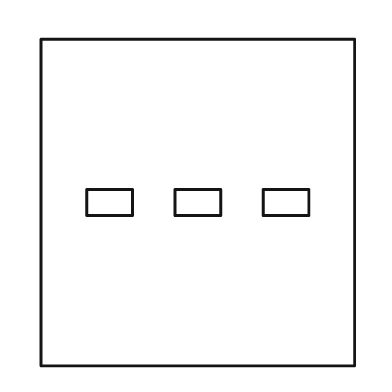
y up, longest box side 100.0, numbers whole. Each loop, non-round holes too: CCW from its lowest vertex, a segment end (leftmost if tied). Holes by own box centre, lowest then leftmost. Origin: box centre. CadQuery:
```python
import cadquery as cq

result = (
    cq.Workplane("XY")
    .moveTo(-48.0, -50.0)
    .lineTo(48.0, -50.0)
    .lineTo(48.0, 50.0)
    .lineTo(-48.0, 50.0)
    .close()
    .moveTo(-34.0, -4.0)
    .lineTo(-20.0, -4.0)
    .lineTo(-20.0, 4.0)
    .lineTo(-34.0, 4.0)
    .close()
    .moveTo(-7.0, -4.0)
    .lineTo(7.0, -4.0)
    .lineTo(7.0, 4.0)
    .lineTo(-7.0, 4.0)
    .close()
    .moveTo(20.0, -4.0)
    .lineTo(34.0, -4.0)
    .lineTo(34.0, 4.0)
    .lineTo(20.0, 4.0)
    .close()
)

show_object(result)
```